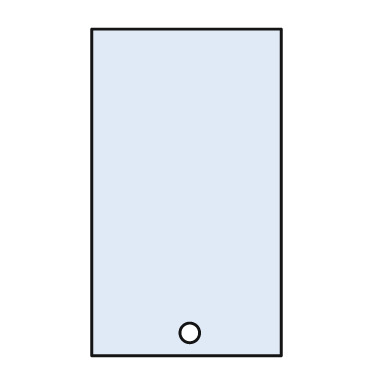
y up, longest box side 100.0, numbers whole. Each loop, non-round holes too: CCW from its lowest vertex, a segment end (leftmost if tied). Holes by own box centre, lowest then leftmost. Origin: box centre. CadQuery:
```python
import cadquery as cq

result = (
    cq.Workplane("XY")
    .moveTo(-29.0, -50.0)
    .lineTo(29.0, -50.0)
    .lineTo(29.0, 50.0)
    .lineTo(-29.0, 50.0)
    .close()
    .moveTo(1.0, -43.0)
    .circle(3.0)
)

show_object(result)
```